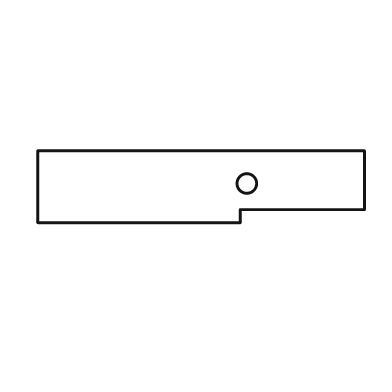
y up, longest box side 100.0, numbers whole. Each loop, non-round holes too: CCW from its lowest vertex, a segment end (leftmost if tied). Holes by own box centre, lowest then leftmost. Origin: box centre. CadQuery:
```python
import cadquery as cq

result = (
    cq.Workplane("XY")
    .moveTo(-50.0, -11.0)
    .lineTo(12.0, -11.0)
    .lineTo(12.0, -7.0)
    .lineTo(50.0, -7.0)
    .lineTo(50.0, 11.0)
    .lineTo(-50.0, 11.0)
    .close()
    .moveTo(14.0, 1.0)
    .circle(3.0)
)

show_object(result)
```